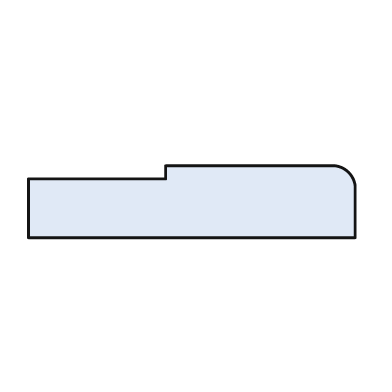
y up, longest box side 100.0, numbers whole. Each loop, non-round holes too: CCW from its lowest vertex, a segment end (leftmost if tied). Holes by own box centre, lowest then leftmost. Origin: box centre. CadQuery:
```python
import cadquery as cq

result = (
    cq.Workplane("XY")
    .moveTo(-50.0, -11.0)
    .lineTo(50.0, -11.0)
    .lineTo(50.0, 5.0)
    .threePointArc((48.0, 9.0), (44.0, 11.0))
    .lineTo(-8.0, 11.0)
    .lineTo(-8.0, 7.0)
    .lineTo(-50.0, 7.0)
    .close()
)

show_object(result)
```